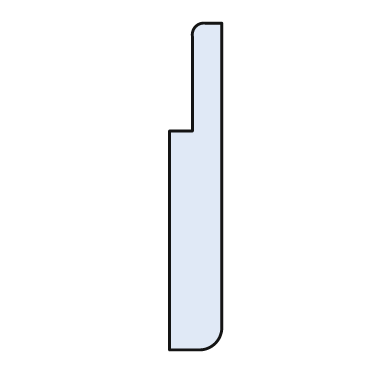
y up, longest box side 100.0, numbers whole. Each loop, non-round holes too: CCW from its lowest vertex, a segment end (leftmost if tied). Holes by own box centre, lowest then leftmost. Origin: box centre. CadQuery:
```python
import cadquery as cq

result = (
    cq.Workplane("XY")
    .moveTo(-8.0, -50.0)
    .lineTo(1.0, -50.0)
    .threePointArc((6.0, -48.0), (8.0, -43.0))
    .lineTo(8.0, 50.0)
    .lineTo(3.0, 50.0)
    .threePointArc((0.0, 49.0), (-1.0, 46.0))
    .lineTo(-1.0, 17.0)
    .lineTo(-8.0, 17.0)
    .close()
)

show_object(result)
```